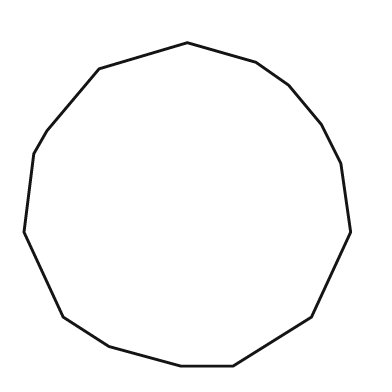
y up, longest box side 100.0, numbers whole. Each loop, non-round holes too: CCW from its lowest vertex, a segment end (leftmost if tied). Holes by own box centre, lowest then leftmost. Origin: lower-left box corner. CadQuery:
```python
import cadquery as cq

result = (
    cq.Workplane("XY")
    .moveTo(48.0, 0.0)
    .lineTo(64.0, 0.0)
    .lineTo(88.0, 15.0)
    .lineTo(100.0, 41.0)
    .lineTo(97.0, 62.0)
    .lineTo(91.0, 74.0)
    .lineTo(81.0, 86.0)
    .lineTo(71.0, 93.0)
    .lineTo(50.0, 99.0)
    .lineTo(23.0, 91.0)
    .lineTo(7.0, 72.0)
    .lineTo(3.0, 65.0)
    .lineTo(0.0, 41.0)
    .lineTo(12.0, 15.0)
    .lineTo(26.0, 6.0)
    .close()
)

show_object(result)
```